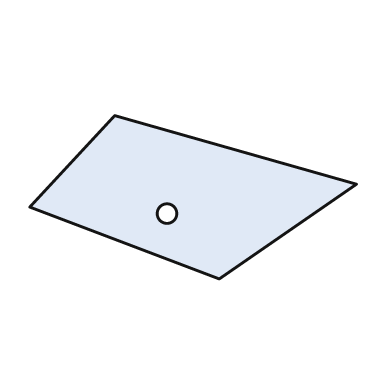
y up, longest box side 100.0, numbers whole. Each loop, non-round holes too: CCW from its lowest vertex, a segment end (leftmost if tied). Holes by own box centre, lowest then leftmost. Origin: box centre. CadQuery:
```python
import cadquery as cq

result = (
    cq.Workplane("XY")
    .moveTo(8.0, -25.0)
    .lineTo(50.0, 4.0)
    .lineTo(-24.0, 25.0)
    .lineTo(-50.0, -3.0)
    .close()
    .moveTo(-8.0, -5.0)
    .circle(3.0)
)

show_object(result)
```